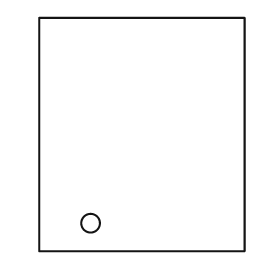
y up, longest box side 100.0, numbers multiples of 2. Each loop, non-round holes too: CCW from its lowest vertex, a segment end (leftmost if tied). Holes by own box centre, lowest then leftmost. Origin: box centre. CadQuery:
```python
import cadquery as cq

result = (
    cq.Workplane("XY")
    .moveTo(-44.0, -50.0)
    .lineTo(44.0, -50.0)
    .lineTo(44.0, 50.0)
    .lineTo(-44.0, 50.0)
    .close()
    .moveTo(-22.0, -38.0)
    .circle(4.0)
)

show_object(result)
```